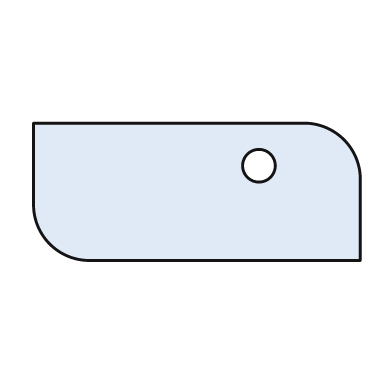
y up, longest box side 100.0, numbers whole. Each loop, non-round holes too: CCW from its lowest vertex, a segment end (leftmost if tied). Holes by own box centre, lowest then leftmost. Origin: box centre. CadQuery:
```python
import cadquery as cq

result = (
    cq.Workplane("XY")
    .moveTo(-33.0, -21.0)
    .lineTo(50.0, -21.0)
    .lineTo(50.0, 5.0)
    .threePointArc((45.0, 16.0), (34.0, 21.0))
    .lineTo(-50.0, 21.0)
    .lineTo(-50.0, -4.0)
    .threePointArc((-45.0, -16.0), (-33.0, -21.0))
    .close()
    .moveTo(19.0, 8.0)
    .circle(5.0)
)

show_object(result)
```